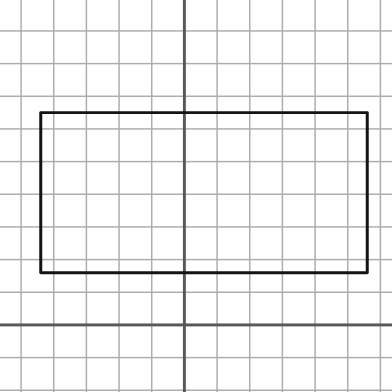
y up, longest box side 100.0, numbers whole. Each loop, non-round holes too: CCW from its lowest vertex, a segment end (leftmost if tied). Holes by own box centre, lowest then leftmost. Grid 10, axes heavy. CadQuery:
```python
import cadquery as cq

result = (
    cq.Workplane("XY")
    .moveTo(-44.0, 16.0)
    .lineTo(56.0, 16.0)
    .lineTo(56.0, 65.0)
    .lineTo(-44.0, 65.0)
    .close()
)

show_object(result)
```